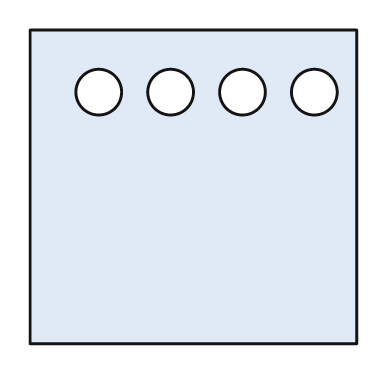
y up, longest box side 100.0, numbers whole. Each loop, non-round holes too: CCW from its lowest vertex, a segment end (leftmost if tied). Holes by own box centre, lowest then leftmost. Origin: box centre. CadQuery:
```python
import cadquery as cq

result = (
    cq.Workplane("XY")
    .moveTo(-50.0, -48.0)
    .lineTo(50.0, -48.0)
    .lineTo(50.0, 48.0)
    .lineTo(-50.0, 48.0)
    .close()
    .moveTo(-29.0, 29.0)
    .circle(7.0)
    .moveTo(-7.0, 29.0)
    .circle(7.0)
    .moveTo(15.0, 29.0)
    .circle(7.0)
    .moveTo(37.0, 29.0)
    .circle(7.0)
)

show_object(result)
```